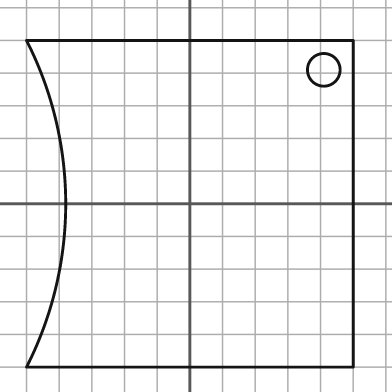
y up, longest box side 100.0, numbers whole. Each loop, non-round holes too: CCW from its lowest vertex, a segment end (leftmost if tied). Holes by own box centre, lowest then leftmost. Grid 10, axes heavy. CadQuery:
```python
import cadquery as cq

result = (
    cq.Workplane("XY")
    .moveTo(-50.0, -50.0)
    .lineTo(50.0, -50.0)
    .lineTo(50.0, 50.0)
    .lineTo(-50.0, 50.0)
    .threePointArc((-38.0, 0.0), (-50.0, -50.0))
    .close()
    .moveTo(41.0, 41.0)
    .circle(5.0)
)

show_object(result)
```